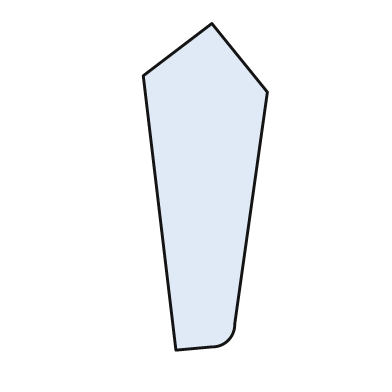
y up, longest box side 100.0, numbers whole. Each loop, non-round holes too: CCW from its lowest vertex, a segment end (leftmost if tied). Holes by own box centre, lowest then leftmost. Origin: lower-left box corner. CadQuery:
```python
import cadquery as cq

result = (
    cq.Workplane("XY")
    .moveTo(10.0, 0.0)
    .lineTo(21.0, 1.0)
    .threePointArc((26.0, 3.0), (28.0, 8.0))
    .lineTo(38.0, 79.0)
    .lineTo(21.0, 100.0)
    .lineTo(0.0, 84.0)
    .close()
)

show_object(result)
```